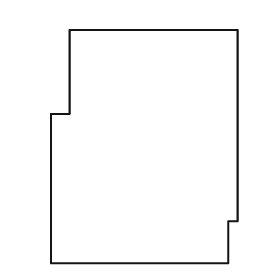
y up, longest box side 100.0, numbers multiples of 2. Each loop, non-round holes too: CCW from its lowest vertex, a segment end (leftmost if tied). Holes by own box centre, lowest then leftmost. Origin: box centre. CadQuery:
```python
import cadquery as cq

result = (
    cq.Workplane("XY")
    .moveTo(-40.0, -50.0)
    .lineTo(36.0, -50.0)
    .lineTo(36.0, -32.0)
    .lineTo(40.0, -32.0)
    .lineTo(40.0, 50.0)
    .lineTo(-32.0, 50.0)
    .lineTo(-32.0, 14.0)
    .lineTo(-40.0, 14.0)
    .close()
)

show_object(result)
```